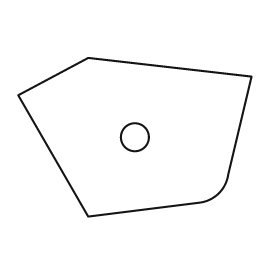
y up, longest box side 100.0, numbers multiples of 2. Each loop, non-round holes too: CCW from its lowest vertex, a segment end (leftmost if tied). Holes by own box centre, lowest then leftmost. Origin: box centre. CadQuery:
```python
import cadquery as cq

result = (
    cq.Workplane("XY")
    .moveTo(-20.0, -34.0)
    .lineTo(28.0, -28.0)
    .threePointArc((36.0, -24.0), (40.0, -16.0))
    .lineTo(50.0, 26.0)
    .lineTo(-20.0, 34.0)
    .lineTo(-50.0, 18.0)
    .close()
    .moveTo(0.0, 0.0)
    .circle(6.0)
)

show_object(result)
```